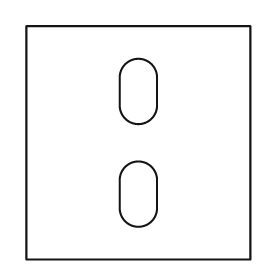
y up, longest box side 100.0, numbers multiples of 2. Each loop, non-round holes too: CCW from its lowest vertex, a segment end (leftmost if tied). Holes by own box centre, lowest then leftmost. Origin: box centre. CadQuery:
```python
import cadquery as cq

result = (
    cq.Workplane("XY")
    .moveTo(-48.0, -50.0)
    .lineTo(48.0, -50.0)
    .lineTo(48.0, 50.0)
    .lineTo(-48.0, 50.0)
    .close()
    .moveTo(-8.0, -28.0)
    .threePointArc((0.0, -36.0), (8.0, -28.0))
    .lineTo(8.0, -16.0)
    .threePointArc((0.0, -8.0), (-8.0, -16.0))
    .close()
    .moveTo(-8.0, 16.0)
    .threePointArc((0.0, 8.0), (8.0, 16.0))
    .lineTo(8.0, 28.0)
    .threePointArc((0.0, 36.0), (-8.0, 28.0))
    .close()
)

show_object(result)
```